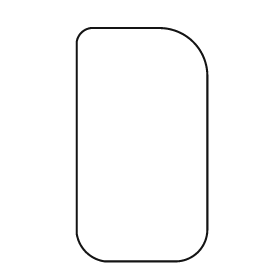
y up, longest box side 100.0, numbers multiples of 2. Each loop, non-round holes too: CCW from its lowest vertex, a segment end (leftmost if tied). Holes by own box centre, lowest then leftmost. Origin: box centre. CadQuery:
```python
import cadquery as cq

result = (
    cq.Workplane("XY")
    .moveTo(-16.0, -50.0)
    .lineTo(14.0, -50.0)
    .threePointArc((24.0, -46.0), (28.0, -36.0))
    .lineTo(28.0, 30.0)
    .threePointArc((22.0, 44.0), (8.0, 50.0))
    .lineTo(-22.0, 50.0)
    .threePointArc((-26.0, 48.0), (-28.0, 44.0))
    .lineTo(-28.0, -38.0)
    .threePointArc((-24.0, -46.0), (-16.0, -50.0))
    .close()
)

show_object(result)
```